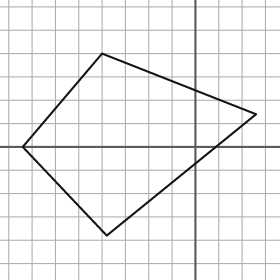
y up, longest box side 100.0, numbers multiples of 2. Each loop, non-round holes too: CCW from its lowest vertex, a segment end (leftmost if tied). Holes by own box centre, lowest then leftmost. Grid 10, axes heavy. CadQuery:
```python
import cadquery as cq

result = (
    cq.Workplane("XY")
    .moveTo(-38.0, -38.0)
    .lineTo(26.0, 14.0)
    .lineTo(-40.0, 40.0)
    .lineTo(-74.0, 0.0)
    .close()
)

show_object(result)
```